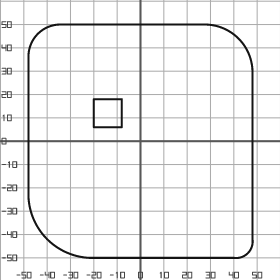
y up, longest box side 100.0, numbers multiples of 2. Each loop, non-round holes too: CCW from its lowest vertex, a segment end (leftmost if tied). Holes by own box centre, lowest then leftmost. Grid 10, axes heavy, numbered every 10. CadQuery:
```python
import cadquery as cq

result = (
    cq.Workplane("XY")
    .moveTo(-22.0, -50.0)
    .lineTo(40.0, -50.0)
    .threePointArc((46.0, -48.0), (48.0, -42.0))
    .lineTo(48.0, 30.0)
    .threePointArc((42.0, 44.0), (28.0, 50.0))
    .lineTo(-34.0, 50.0)
    .threePointArc((-44.0, 46.0), (-48.0, 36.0))
    .lineTo(-48.0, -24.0)
    .threePointArc((-40.0, -42.0), (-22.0, -50.0))
    .close()
    .moveTo(-20.0, 6.0)
    .lineTo(-8.0, 6.0)
    .lineTo(-8.0, 18.0)
    .lineTo(-20.0, 18.0)
    .close()
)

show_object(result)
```